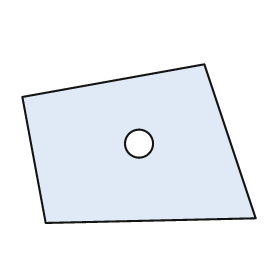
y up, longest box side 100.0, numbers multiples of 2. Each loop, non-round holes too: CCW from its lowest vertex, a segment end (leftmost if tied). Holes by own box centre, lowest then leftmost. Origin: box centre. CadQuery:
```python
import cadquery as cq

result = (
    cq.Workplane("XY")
    .moveTo(-40.0, -34.0)
    .lineTo(50.0, -32.0)
    .lineTo(28.0, 34.0)
    .lineTo(-50.0, 20.0)
    .close()
    .moveTo(0.0, 0.0)
    .circle(6.0)
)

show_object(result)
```